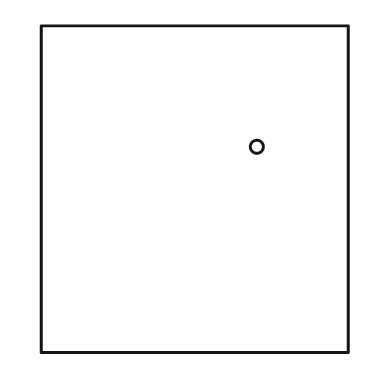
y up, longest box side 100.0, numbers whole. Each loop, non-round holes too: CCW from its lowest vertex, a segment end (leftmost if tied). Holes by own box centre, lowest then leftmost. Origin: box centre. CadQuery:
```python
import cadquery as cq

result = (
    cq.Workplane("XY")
    .moveTo(-47.0, -50.0)
    .lineTo(47.0, -50.0)
    .lineTo(47.0, 50.0)
    .lineTo(-47.0, 50.0)
    .close()
    .moveTo(19.0, 13.0)
    .circle(2.0)
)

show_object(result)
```